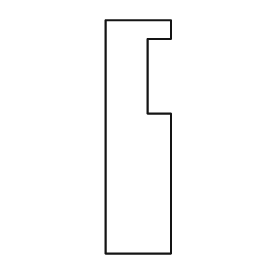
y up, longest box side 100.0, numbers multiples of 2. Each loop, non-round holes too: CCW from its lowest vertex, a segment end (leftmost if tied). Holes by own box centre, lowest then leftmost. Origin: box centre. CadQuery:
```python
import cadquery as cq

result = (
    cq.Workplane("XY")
    .moveTo(-14.0, -50.0)
    .lineTo(14.0, -50.0)
    .lineTo(14.0, 10.0)
    .lineTo(4.0, 10.0)
    .lineTo(4.0, 42.0)
    .lineTo(14.0, 42.0)
    .lineTo(14.0, 50.0)
    .lineTo(-14.0, 50.0)
    .close()
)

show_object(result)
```